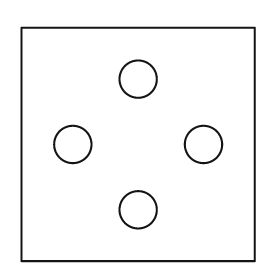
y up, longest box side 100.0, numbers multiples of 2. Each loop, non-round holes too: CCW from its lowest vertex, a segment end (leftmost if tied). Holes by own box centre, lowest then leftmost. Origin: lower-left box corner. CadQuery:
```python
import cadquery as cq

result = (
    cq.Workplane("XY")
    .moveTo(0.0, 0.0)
    .lineTo(100.0, 0.0)
    .lineTo(100.0, 100.0)
    .lineTo(0.0, 100.0)
    .close()
    .moveTo(50.0, 22.0)
    .circle(8.0)
    .moveTo(22.0, 50.0)
    .circle(8.0)
    .moveTo(78.0, 50.0)
    .circle(8.0)
    .moveTo(50.0, 78.0)
    .circle(8.0)
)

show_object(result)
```